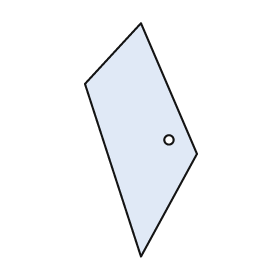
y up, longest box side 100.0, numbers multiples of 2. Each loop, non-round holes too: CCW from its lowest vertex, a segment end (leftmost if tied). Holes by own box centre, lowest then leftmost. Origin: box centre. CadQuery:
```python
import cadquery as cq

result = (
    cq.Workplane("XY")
    .moveTo(0.0, -50.0)
    .lineTo(24.0, -6.0)
    .lineTo(0.0, 50.0)
    .lineTo(-24.0, 24.0)
    .close()
    .moveTo(12.0, 0.0)
    .circle(2.0)
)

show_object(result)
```